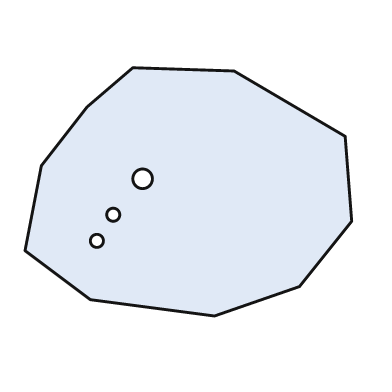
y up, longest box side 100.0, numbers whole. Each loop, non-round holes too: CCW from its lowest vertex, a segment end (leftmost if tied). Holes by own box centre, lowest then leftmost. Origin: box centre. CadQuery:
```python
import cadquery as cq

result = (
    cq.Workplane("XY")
    .moveTo(8.0, -38.0)
    .lineTo(34.0, -29.0)
    .lineTo(50.0, -9.0)
    .lineTo(48.0, 17.0)
    .lineTo(14.0, 37.0)
    .lineTo(-17.0, 38.0)
    .lineTo(-31.0, 26.0)
    .lineTo(-45.0, 8.0)
    .lineTo(-50.0, -18.0)
    .lineTo(-30.0, -33.0)
    .close()
    .moveTo(-28.0, -15.0)
    .circle(2.0)
    .moveTo(-23.0, -7.0)
    .circle(2.0)
    .moveTo(-14.0, 4.0)
    .circle(3.0)
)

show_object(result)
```